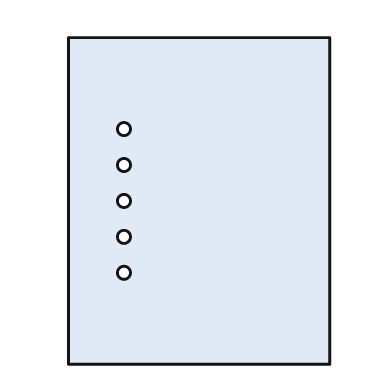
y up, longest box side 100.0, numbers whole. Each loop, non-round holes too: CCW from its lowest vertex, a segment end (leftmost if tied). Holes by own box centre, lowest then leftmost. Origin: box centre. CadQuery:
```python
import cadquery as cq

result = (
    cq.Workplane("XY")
    .moveTo(-40.0, -50.0)
    .lineTo(40.0, -50.0)
    .lineTo(40.0, 50.0)
    .lineTo(-40.0, 50.0)
    .close()
    .moveTo(-23.0, -22.0)
    .circle(2.0)
    .moveTo(-23.0, -11.0)
    .circle(2.0)
    .moveTo(-23.0, 0.0)
    .circle(2.0)
    .moveTo(-23.0, 11.0)
    .circle(2.0)
    .moveTo(-23.0, 22.0)
    .circle(2.0)
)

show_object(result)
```